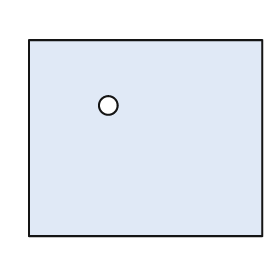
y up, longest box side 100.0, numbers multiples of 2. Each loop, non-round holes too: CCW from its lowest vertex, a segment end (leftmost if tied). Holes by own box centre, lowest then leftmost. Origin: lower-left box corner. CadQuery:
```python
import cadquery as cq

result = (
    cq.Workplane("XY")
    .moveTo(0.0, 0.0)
    .lineTo(100.0, 0.0)
    .lineTo(100.0, 84.0)
    .lineTo(0.0, 84.0)
    .close()
    .moveTo(34.0, 56.0)
    .circle(4.0)
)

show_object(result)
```